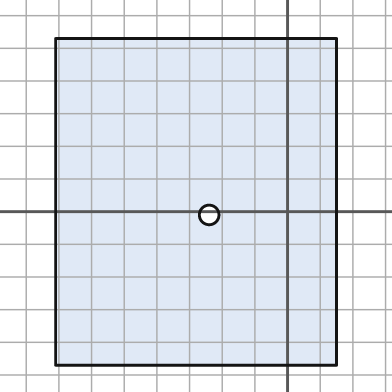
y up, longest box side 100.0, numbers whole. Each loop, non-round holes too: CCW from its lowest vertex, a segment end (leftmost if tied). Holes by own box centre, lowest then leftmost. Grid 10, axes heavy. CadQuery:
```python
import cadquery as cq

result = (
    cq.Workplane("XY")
    .moveTo(-71.0, -47.0)
    .lineTo(15.0, -47.0)
    .lineTo(15.0, 53.0)
    .lineTo(-71.0, 53.0)
    .close()
    .moveTo(-24.0, -1.0)
    .circle(3.0)
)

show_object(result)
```